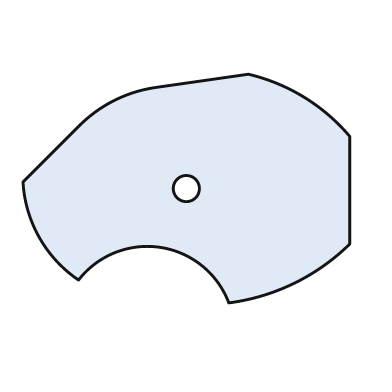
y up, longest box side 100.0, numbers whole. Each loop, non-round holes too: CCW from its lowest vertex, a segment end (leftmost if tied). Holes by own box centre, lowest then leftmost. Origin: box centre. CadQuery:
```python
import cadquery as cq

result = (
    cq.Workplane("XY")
    .moveTo(13.0, -35.0)
    .threePointArc((33.0, -29.0), (50.0, -17.0))
    .lineTo(50.0, 16.0)
    .threePointArc((36.0, 28.0), (19.0, 35.0))
    .lineTo(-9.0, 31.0)
    .threePointArc((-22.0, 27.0), (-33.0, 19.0))
    .lineTo(-50.0, 2.0)
    .threePointArc((-45.0, -15.0), (-33.0, -28.0))
    .threePointArc((-8.0, -18.0), (13.0, -35.0))
    .close()
    .moveTo(0.0, 0.0)
    .circle(4.0)
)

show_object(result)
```